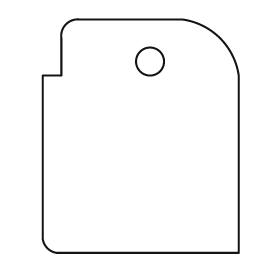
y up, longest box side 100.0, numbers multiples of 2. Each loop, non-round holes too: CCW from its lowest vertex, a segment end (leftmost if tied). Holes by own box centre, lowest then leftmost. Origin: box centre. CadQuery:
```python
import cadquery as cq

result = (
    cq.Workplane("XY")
    .moveTo(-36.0, -50.0)
    .lineTo(42.0, -50.0)
    .lineTo(42.0, 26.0)
    .threePointArc((34.0, 42.0), (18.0, 50.0))
    .lineTo(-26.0, 50.0)
    .threePointArc((-32.0, 48.0), (-34.0, 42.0))
    .lineTo(-34.0, 26.0)
    .lineTo(-42.0, 26.0)
    .lineTo(-42.0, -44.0)
    .threePointArc((-40.0, -48.0), (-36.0, -50.0))
    .close()
    .moveTo(4.0, 32.0)
    .circle(6.0)
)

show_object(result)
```